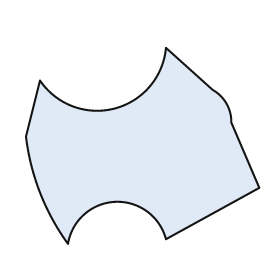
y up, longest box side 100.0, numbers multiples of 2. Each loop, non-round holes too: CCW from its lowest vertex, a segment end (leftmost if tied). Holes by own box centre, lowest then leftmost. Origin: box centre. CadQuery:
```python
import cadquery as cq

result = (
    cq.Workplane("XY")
    .moveTo(-32.0, -42.0)
    .threePointArc((-12.0, -24.0), (10.0, -40.0))
    .lineTo(50.0, -18.0)
    .lineTo(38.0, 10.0)
    .threePointArc((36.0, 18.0), (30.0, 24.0))
    .lineTo(10.0, 42.0)
    .threePointArc((-12.0, 16.0), (-44.0, 28.0))
    .lineTo(-50.0, 4.0)
    .threePointArc((-44.0, -20.0), (-32.0, -42.0))
    .close()
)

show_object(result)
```